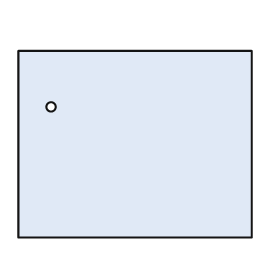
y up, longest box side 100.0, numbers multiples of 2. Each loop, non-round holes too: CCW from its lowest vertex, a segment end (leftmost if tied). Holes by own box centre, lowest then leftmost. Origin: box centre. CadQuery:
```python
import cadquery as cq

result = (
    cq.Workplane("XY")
    .moveTo(-50.0, -40.0)
    .lineTo(50.0, -40.0)
    .lineTo(50.0, 40.0)
    .lineTo(-50.0, 40.0)
    .close()
    .moveTo(-36.0, 16.0)
    .circle(2.0)
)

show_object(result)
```